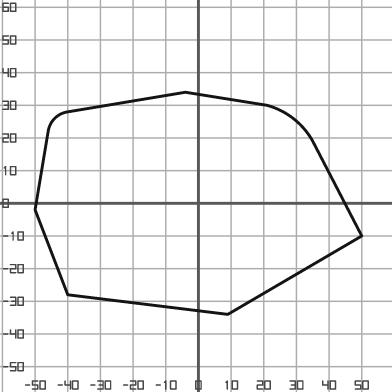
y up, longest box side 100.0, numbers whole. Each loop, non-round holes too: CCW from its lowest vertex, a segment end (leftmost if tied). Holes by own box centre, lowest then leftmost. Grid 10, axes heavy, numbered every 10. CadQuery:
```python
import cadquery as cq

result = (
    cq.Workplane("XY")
    .moveTo(9.0, -34.0)
    .lineTo(50.0, -10.0)
    .lineTo(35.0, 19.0)
    .threePointArc((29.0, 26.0), (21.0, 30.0))
    .lineTo(-4.0, 34.0)
    .lineTo(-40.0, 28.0)
    .threePointArc((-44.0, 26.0), (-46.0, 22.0))
    .lineTo(-50.0, -2.0)
    .lineTo(-40.0, -28.0)
    .close()
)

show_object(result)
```